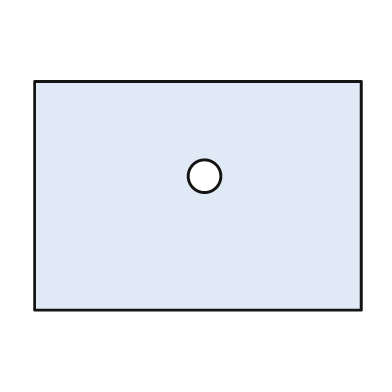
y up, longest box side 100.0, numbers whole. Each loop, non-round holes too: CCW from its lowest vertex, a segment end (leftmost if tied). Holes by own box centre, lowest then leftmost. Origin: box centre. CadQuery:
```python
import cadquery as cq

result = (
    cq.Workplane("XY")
    .moveTo(-50.0, -35.0)
    .lineTo(50.0, -35.0)
    .lineTo(50.0, 35.0)
    .lineTo(-50.0, 35.0)
    .close()
    .moveTo(2.0, 6.0)
    .circle(5.0)
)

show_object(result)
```